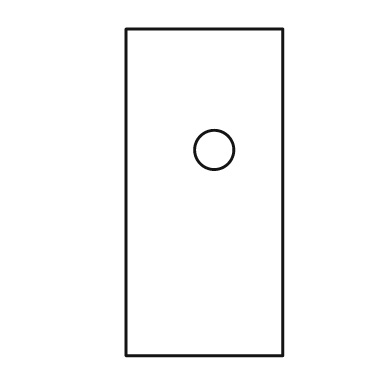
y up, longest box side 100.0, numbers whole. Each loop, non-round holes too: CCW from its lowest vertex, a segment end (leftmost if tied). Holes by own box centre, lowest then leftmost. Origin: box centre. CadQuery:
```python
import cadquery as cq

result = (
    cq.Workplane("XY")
    .moveTo(-24.0, -50.0)
    .lineTo(24.0, -50.0)
    .lineTo(24.0, 50.0)
    .lineTo(-24.0, 50.0)
    .close()
    .moveTo(3.0, 13.0)
    .circle(6.0)
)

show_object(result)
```